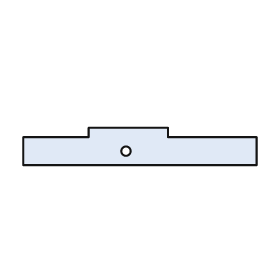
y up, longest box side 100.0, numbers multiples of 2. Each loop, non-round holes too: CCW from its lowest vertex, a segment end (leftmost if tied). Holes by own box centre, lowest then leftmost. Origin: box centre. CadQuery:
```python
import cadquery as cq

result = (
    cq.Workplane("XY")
    .moveTo(-50.0, -8.0)
    .lineTo(50.0, -8.0)
    .lineTo(50.0, 4.0)
    .lineTo(12.0, 4.0)
    .lineTo(12.0, 8.0)
    .lineTo(-22.0, 8.0)
    .lineTo(-22.0, 4.0)
    .lineTo(-50.0, 4.0)
    .close()
    .moveTo(-6.0, -2.0)
    .circle(2.0)
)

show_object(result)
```